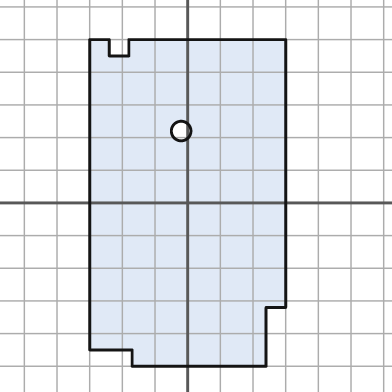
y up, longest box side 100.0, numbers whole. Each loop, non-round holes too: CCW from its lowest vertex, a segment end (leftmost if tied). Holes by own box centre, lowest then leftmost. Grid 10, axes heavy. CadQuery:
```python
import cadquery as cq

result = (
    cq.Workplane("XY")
    .moveTo(-17.0, -50.0)
    .lineTo(24.0, -50.0)
    .lineTo(24.0, -32.0)
    .lineTo(30.0, -32.0)
    .lineTo(30.0, 50.0)
    .lineTo(-18.0, 50.0)
    .lineTo(-18.0, 45.0)
    .lineTo(-24.0, 45.0)
    .lineTo(-24.0, 50.0)
    .lineTo(-30.0, 50.0)
    .lineTo(-30.0, -45.0)
    .lineTo(-17.0, -45.0)
    .close()
    .moveTo(-2.0, 22.0)
    .circle(3.0)
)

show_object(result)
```